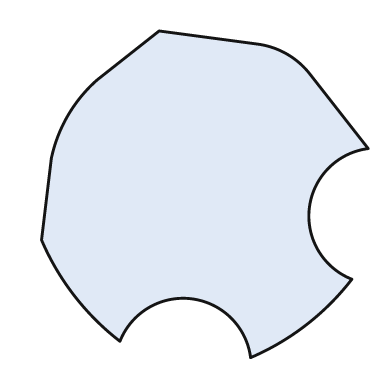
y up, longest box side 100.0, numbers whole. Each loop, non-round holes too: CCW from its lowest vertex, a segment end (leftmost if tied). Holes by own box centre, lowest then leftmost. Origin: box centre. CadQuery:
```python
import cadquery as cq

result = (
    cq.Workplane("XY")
    .moveTo(14.0, -50.0)
    .threePointArc((31.0, -40.0), (45.0, -26.0))
    .threePointArc((32.0, -4.0), (50.0, 14.0))
    .lineTo(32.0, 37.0)
    .threePointArc((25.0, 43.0), (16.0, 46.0))
    .lineTo(-14.0, 50.0)
    .lineTo(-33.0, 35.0)
    .threePointArc((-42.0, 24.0), (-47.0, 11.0))
    .lineTo(-50.0, -14.0)
    .threePointArc((-40.0, -31.0), (-26.0, -45.0))
    .threePointArc((-4.0, -32.0), (14.0, -50.0))
    .close()
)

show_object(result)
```